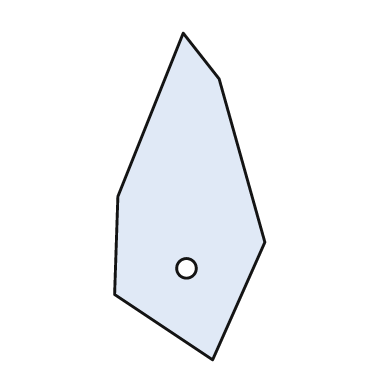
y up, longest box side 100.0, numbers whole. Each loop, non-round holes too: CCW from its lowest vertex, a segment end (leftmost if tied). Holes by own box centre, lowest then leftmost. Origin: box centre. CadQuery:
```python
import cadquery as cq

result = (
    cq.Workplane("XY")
    .moveTo(7.0, -50.0)
    .lineTo(23.0, -14.0)
    .lineTo(9.0, 36.0)
    .lineTo(-2.0, 50.0)
    .lineTo(-22.0, 0.0)
    .lineTo(-23.0, -30.0)
    .close()
    .moveTo(-1.0, -22.0)
    .circle(3.0)
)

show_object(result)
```